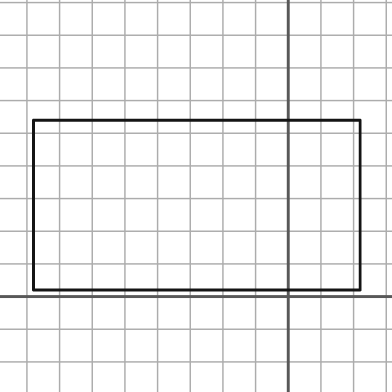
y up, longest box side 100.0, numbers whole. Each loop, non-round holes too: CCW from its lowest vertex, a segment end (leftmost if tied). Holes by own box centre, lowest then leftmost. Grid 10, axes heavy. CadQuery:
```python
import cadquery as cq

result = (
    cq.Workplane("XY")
    .moveTo(-78.0, 2.0)
    .lineTo(22.0, 2.0)
    .lineTo(22.0, 54.0)
    .lineTo(-78.0, 54.0)
    .close()
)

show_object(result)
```